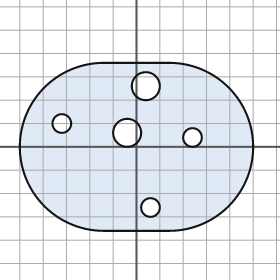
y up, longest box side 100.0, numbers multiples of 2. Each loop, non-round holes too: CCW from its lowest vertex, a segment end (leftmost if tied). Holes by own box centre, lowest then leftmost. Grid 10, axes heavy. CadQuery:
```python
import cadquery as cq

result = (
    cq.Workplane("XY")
    .moveTo(-14.0, -36.0)
    .lineTo(14.0, -36.0)
    .threePointArc((50.0, 0.0), (14.0, 36.0))
    .lineTo(-14.0, 36.0)
    .threePointArc((-50.0, 0.0), (-14.0, -36.0))
    .close()
    .moveTo(6.0, -26.0)
    .circle(4.0)
    .moveTo(24.0, 4.0)
    .circle(4.0)
    .moveTo(-4.0, 6.0)
    .circle(6.0)
    .moveTo(-32.0, 10.0)
    .circle(4.0)
    .moveTo(4.0, 26.0)
    .circle(6.0)
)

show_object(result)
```